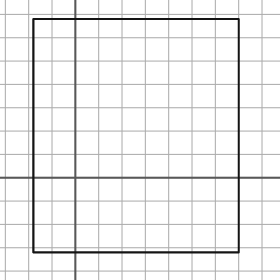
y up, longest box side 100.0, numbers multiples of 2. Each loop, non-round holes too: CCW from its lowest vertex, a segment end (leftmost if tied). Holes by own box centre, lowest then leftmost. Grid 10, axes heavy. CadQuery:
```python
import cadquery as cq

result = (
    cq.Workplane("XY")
    .moveTo(-18.0, -32.0)
    .lineTo(70.0, -32.0)
    .lineTo(70.0, 68.0)
    .lineTo(-18.0, 68.0)
    .close()
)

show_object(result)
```